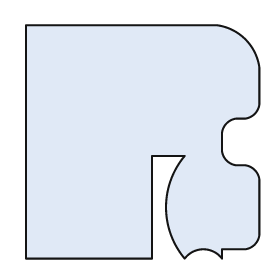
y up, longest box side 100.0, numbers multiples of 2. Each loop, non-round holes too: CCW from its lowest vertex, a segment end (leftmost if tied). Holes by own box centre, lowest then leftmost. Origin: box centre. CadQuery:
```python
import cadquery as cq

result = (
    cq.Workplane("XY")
    .moveTo(-50.0, -50.0)
    .lineTo(4.0, -50.0)
    .lineTo(4.0, -6.0)
    .lineTo(18.0, -6.0)
    .threePointArc((10.0, -28.0), (18.0, -50.0))
    .threePointArc((26.0, -46.0), (34.0, -50.0))
    .lineTo(34.0, -46.0)
    .lineTo(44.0, -46.0)
    .threePointArc((48.0, -44.0), (50.0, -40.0))
    .lineTo(50.0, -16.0)
    .threePointArc((48.0, -12.0), (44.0, -10.0))
    .lineTo(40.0, -10.0)
    .threePointArc((36.0, -8.0), (34.0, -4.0))
    .lineTo(34.0, 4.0)
    .threePointArc((36.0, 8.0), (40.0, 10.0))
    .lineTo(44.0, 10.0)
    .threePointArc((48.0, 12.0), (50.0, 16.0))
    .lineTo(50.0, 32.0)
    .threePointArc((44.0, 44.0), (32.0, 50.0))
    .lineTo(-50.0, 50.0)
    .close()
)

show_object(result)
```